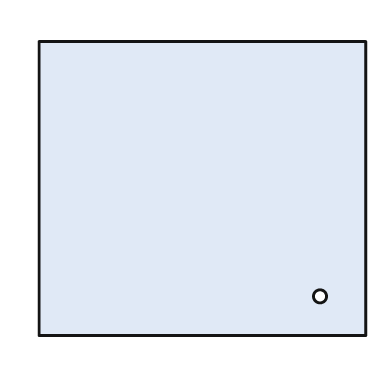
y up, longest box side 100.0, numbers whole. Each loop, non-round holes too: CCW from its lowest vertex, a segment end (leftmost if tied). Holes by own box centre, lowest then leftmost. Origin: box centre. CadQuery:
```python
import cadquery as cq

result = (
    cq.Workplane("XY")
    .moveTo(-50.0, -45.0)
    .lineTo(50.0, -45.0)
    .lineTo(50.0, 45.0)
    .lineTo(-50.0, 45.0)
    .close()
    .moveTo(36.0, -33.0)
    .circle(2.0)
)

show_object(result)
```